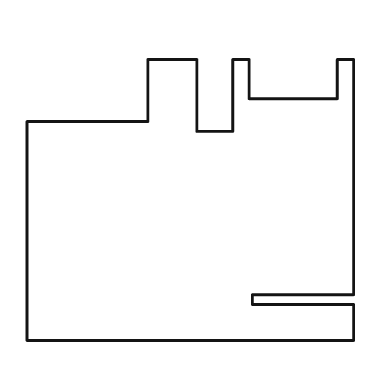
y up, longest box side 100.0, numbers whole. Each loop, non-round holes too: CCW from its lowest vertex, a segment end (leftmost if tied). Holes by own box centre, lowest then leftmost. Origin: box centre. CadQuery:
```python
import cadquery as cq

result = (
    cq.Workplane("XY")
    .moveTo(-50.0, -43.0)
    .lineTo(50.0, -43.0)
    .lineTo(50.0, -32.0)
    .lineTo(19.0, -32.0)
    .lineTo(19.0, -29.0)
    .lineTo(50.0, -29.0)
    .lineTo(50.0, 43.0)
    .lineTo(45.0, 43.0)
    .lineTo(45.0, 31.0)
    .lineTo(18.0, 31.0)
    .lineTo(18.0, 43.0)
    .lineTo(13.0, 43.0)
    .lineTo(13.0, 21.0)
    .lineTo(2.0, 21.0)
    .lineTo(2.0, 43.0)
    .lineTo(-13.0, 43.0)
    .lineTo(-13.0, 24.0)
    .lineTo(-50.0, 24.0)
    .close()
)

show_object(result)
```